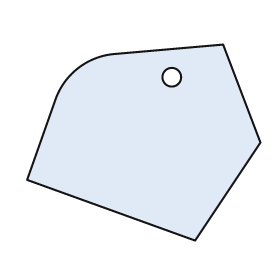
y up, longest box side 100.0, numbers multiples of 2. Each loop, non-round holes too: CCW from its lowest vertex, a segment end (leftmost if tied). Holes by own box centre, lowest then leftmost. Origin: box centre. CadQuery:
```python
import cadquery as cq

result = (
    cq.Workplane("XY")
    .moveTo(22.0, -42.0)
    .lineTo(50.0, 0.0)
    .lineTo(34.0, 42.0)
    .lineTo(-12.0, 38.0)
    .threePointArc((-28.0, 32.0), (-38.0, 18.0))
    .lineTo(-50.0, -16.0)
    .close()
    .moveTo(12.0, 28.0)
    .circle(4.0)
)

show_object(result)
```